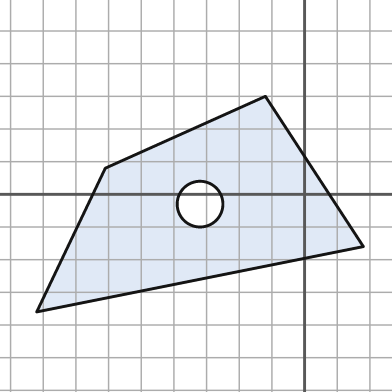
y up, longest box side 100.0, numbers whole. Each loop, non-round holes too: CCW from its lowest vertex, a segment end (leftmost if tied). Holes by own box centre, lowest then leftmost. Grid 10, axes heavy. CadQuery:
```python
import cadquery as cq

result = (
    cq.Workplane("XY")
    .moveTo(-82.0, -36.0)
    .lineTo(18.0, -16.0)
    .lineTo(-12.0, 30.0)
    .lineTo(-61.0, 8.0)
    .close()
    .moveTo(-32.0, -3.0)
    .circle(7.0)
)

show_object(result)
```